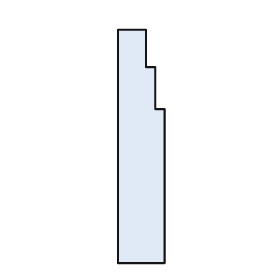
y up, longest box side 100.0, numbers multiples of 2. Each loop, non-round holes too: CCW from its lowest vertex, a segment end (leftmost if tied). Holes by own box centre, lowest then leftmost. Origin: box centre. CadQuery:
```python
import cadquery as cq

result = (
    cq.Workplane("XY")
    .moveTo(-10.0, -50.0)
    .lineTo(10.0, -50.0)
    .lineTo(10.0, 16.0)
    .lineTo(6.0, 16.0)
    .lineTo(6.0, 34.0)
    .lineTo(2.0, 34.0)
    .lineTo(2.0, 50.0)
    .lineTo(-10.0, 50.0)
    .close()
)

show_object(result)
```